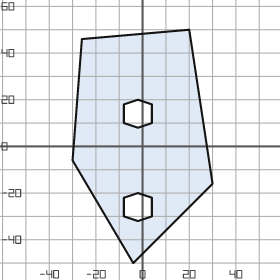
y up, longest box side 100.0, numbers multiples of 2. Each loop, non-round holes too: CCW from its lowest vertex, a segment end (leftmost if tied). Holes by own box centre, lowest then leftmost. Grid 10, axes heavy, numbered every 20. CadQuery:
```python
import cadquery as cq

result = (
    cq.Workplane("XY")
    .moveTo(-4.0, -50.0)
    .lineTo(30.0, -16.0)
    .lineTo(20.0, 50.0)
    .lineTo(-26.0, 46.0)
    .lineTo(-30.0, -6.0)
    .close()
    .moveTo(-2.0, -32.0)
    .lineTo(4.0, -30.0)
    .lineTo(4.0, -22.0)
    .lineTo(-2.0, -20.0)
    .lineTo(-8.0, -22.0)
    .lineTo(-8.0, -30.0)
    .close()
    .moveTo(-2.0, 8.0)
    .lineTo(4.0, 10.0)
    .lineTo(4.0, 18.0)
    .lineTo(-2.0, 20.0)
    .lineTo(-8.0, 18.0)
    .lineTo(-8.0, 10.0)
    .close()
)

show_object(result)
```